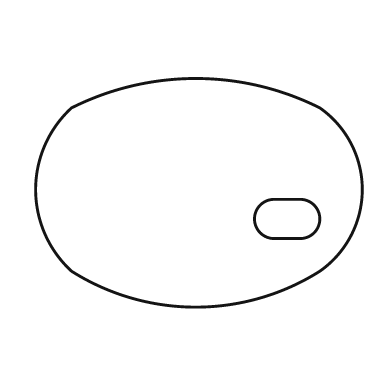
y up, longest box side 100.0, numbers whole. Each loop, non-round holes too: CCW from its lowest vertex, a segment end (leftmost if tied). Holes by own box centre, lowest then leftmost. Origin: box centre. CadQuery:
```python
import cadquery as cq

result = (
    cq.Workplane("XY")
    .moveTo(-39.0, -24.0)
    .threePointArc((-1.0, -35.0), (37.0, -24.0))
    .threePointArc((50.0, 1.0), (37.0, 26.0))
    .threePointArc((-1.0, 35.0), (-39.0, 26.0))
    .threePointArc((-50.0, 1.0), (-39.0, -24.0))
    .close()
    .moveTo(23.0, -14.0)
    .lineTo(31.0, -14.0)
    .threePointArc((37.0, -8.0), (31.0, -2.0))
    .lineTo(23.0, -2.0)
    .threePointArc((17.0, -8.0), (23.0, -14.0))
    .close()
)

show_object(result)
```